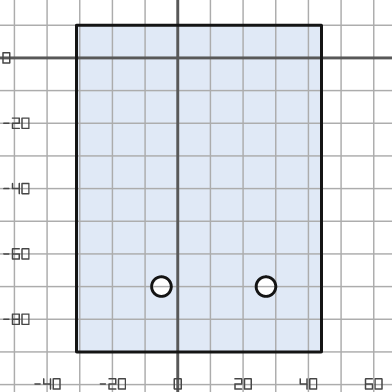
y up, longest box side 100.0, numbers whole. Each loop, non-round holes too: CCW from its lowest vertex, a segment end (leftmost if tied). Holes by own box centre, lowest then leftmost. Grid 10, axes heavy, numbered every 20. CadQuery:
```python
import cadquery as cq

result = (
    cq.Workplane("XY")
    .moveTo(-31.0, -90.0)
    .lineTo(44.0, -90.0)
    .lineTo(44.0, 10.0)
    .lineTo(-31.0, 10.0)
    .close()
    .moveTo(-5.0, -70.0)
    .circle(3.0)
    .moveTo(27.0, -70.0)
    .circle(3.0)
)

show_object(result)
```